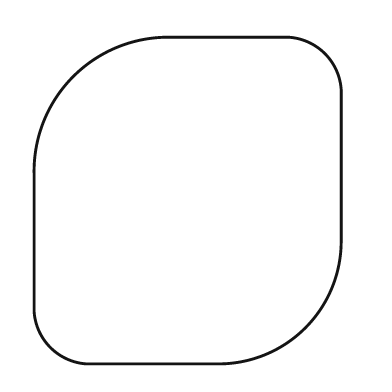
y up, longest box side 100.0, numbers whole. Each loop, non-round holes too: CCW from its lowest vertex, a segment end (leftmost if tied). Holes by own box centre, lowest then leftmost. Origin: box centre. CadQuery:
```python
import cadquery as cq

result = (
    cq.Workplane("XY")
    .moveTo(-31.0, -50.0)
    .lineTo(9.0, -50.0)
    .threePointArc((36.0, -39.0), (47.0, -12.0))
    .lineTo(47.0, 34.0)
    .threePointArc((42.0, 45.0), (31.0, 50.0))
    .lineTo(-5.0, 50.0)
    .threePointArc((-35.0, 38.0), (-47.0, 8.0))
    .lineTo(-47.0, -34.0)
    .threePointArc((-42.0, -45.0), (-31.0, -50.0))
    .close()
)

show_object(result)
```